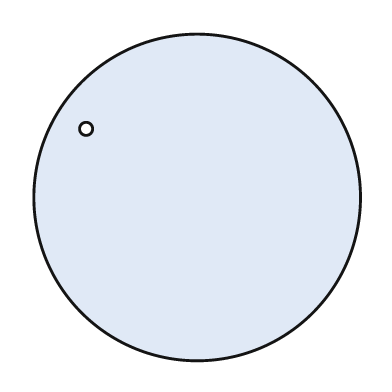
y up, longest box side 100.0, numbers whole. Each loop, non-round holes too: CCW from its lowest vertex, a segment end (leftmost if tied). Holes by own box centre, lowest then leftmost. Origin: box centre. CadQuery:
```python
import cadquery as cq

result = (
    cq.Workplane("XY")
    .moveTo(0.0, 0.0)
    .circle(50.0)
    .moveTo(-34.0, 21.0)
    .circle(2.0)
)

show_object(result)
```